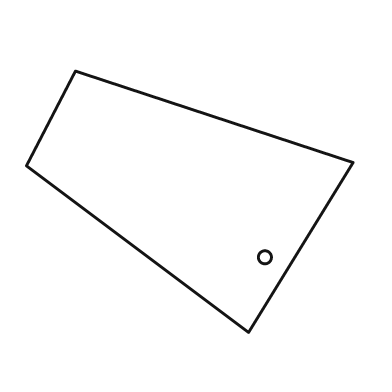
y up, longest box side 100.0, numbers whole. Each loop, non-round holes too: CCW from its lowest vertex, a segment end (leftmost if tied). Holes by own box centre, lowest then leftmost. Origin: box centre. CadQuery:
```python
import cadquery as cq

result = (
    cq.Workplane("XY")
    .moveTo(18.0, -40.0)
    .lineTo(50.0, 12.0)
    .lineTo(-35.0, 40.0)
    .lineTo(-50.0, 11.0)
    .close()
    .moveTo(23.0, -17.0)
    .circle(2.0)
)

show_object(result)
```